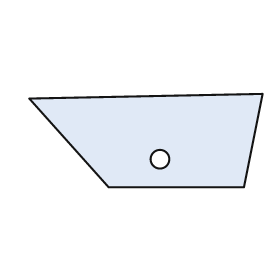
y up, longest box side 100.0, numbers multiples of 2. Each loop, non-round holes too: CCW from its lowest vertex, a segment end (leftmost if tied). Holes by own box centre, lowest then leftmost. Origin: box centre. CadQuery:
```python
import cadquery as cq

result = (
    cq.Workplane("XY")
    .moveTo(-16.0, -20.0)
    .lineTo(42.0, -20.0)
    .lineTo(50.0, 20.0)
    .lineTo(-50.0, 18.0)
    .close()
    .moveTo(6.0, -8.0)
    .circle(4.0)
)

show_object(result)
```